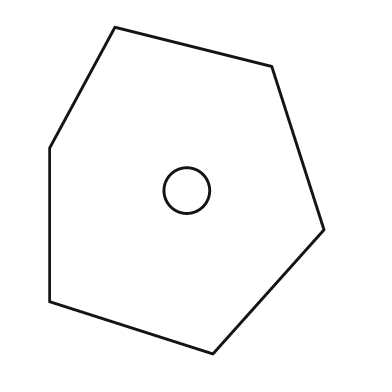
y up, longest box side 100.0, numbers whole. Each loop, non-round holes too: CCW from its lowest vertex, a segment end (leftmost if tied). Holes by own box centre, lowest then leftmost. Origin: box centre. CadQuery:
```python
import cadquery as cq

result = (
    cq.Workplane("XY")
    .moveTo(8.0, -50.0)
    .lineTo(42.0, -12.0)
    .lineTo(26.0, 38.0)
    .lineTo(-22.0, 50.0)
    .lineTo(-42.0, 13.0)
    .lineTo(-42.0, -34.0)
    .close()
    .moveTo(0.0, 0.0)
    .circle(7.0)
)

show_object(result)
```